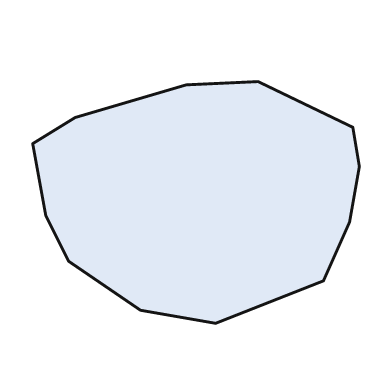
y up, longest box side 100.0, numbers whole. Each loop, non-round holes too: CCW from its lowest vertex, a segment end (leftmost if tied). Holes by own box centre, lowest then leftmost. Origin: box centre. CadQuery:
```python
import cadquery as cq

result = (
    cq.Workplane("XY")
    .moveTo(6.0, -37.0)
    .lineTo(39.0, -24.0)
    .lineTo(47.0, -6.0)
    .lineTo(50.0, 11.0)
    .lineTo(48.0, 23.0)
    .lineTo(19.0, 37.0)
    .lineTo(-3.0, 36.0)
    .lineTo(-37.0, 26.0)
    .lineTo(-50.0, 18.0)
    .lineTo(-46.0, -4.0)
    .lineTo(-39.0, -18.0)
    .lineTo(-17.0, -33.0)
    .close()
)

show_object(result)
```